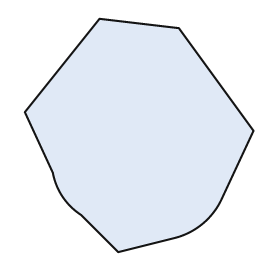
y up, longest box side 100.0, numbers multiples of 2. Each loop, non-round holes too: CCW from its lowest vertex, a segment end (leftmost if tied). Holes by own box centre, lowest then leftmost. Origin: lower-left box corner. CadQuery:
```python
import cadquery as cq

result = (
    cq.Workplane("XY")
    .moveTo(40.0, 0.0)
    .lineTo(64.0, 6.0)
    .threePointArc((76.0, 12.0), (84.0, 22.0))
    .lineTo(98.0, 52.0)
    .lineTo(66.0, 96.0)
    .lineTo(32.0, 100.0)
    .lineTo(0.0, 60.0)
    .lineTo(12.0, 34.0)
    .threePointArc((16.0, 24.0), (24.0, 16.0))
    .close()
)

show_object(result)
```